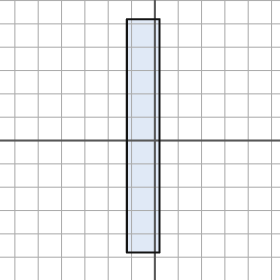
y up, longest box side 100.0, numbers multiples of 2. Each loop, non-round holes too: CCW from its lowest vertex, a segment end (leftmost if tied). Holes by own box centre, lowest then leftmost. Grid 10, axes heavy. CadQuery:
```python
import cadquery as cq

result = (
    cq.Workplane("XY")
    .moveTo(-12.0, -48.0)
    .lineTo(2.0, -48.0)
    .lineTo(2.0, 52.0)
    .lineTo(-12.0, 52.0)
    .close()
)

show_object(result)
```